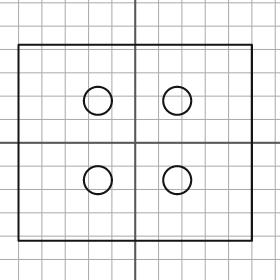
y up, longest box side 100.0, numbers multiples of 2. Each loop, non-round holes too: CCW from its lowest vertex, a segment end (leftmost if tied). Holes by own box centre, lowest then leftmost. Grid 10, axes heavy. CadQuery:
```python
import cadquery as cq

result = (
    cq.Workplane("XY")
    .moveTo(-50.0, -42.0)
    .lineTo(50.0, -42.0)
    .lineTo(50.0, 42.0)
    .lineTo(-50.0, 42.0)
    .close()
    .moveTo(-16.0, -16.0)
    .circle(6.0)
    .moveTo(18.0, -16.0)
    .circle(6.0)
    .moveTo(-16.0, 18.0)
    .circle(6.0)
    .moveTo(18.0, 18.0)
    .circle(6.0)
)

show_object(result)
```